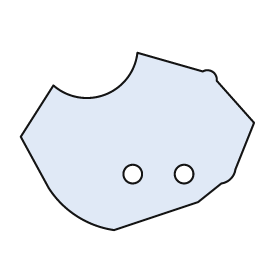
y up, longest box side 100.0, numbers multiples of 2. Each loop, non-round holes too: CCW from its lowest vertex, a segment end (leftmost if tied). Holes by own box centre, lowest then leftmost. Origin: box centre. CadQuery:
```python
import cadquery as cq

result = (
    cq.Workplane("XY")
    .moveTo(-10.0, -38.0)
    .lineTo(26.0, -26.0)
    .lineTo(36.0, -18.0)
    .threePointArc((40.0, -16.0), (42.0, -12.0))
    .lineTo(50.0, 8.0)
    .lineTo(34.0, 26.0)
    .threePointArc((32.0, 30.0), (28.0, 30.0))
    .lineTo(0.0, 38.0)
    .threePointArc((-14.0, 20.0), (-36.0, 24.0))
    .lineTo(-50.0, 2.0)
    .lineTo(-38.0, -20.0)
    .threePointArc((-26.0, -32.0), (-10.0, -38.0))
    .close()
    .moveTo(-2.0, -14.0)
    .circle(4.0)
    .moveTo(20.0, -14.0)
    .circle(4.0)
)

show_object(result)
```